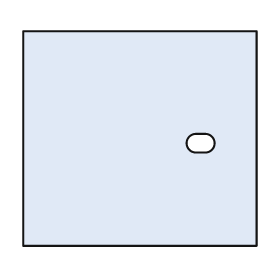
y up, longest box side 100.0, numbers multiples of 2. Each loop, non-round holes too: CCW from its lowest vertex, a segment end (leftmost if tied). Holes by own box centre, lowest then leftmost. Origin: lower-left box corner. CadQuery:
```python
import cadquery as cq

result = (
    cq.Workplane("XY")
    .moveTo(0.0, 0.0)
    .lineTo(100.0, 0.0)
    .lineTo(100.0, 92.0)
    .lineTo(0.0, 92.0)
    .close()
    .moveTo(74.0, 40.0)
    .lineTo(78.0, 40.0)
    .threePointArc((82.0, 44.0), (78.0, 48.0))
    .lineTo(74.0, 48.0)
    .threePointArc((70.0, 44.0), (74.0, 40.0))
    .close()
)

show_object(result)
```